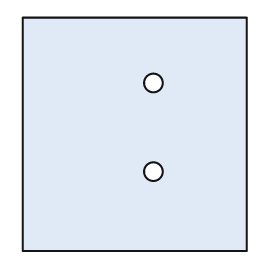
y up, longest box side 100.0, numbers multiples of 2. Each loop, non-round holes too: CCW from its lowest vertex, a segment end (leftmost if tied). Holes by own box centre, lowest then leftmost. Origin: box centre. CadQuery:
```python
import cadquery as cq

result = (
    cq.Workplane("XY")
    .moveTo(-48.0, -50.0)
    .lineTo(48.0, -50.0)
    .lineTo(48.0, 50.0)
    .lineTo(-48.0, 50.0)
    .close()
    .moveTo(8.0, -16.0)
    .circle(4.0)
    .moveTo(8.0, 22.0)
    .circle(4.0)
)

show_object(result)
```